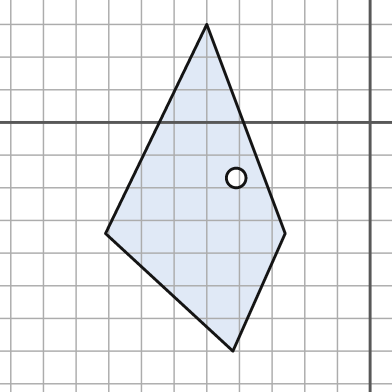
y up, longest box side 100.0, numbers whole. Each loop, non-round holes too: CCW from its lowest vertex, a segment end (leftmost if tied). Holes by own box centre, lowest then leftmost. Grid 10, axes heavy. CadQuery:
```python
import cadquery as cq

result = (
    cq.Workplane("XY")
    .moveTo(-42.0, -70.0)
    .lineTo(-26.0, -34.0)
    .lineTo(-50.0, 30.0)
    .lineTo(-81.0, -34.0)
    .close()
    .moveTo(-41.0, -17.0)
    .circle(3.0)
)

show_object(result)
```